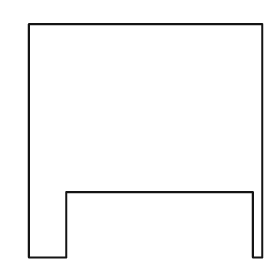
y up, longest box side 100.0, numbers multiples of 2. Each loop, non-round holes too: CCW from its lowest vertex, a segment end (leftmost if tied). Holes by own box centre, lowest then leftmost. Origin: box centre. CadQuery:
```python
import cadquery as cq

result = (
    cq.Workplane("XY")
    .moveTo(-50.0, -50.0)
    .lineTo(-34.0, -50.0)
    .lineTo(-34.0, -22.0)
    .lineTo(46.0, -22.0)
    .lineTo(46.0, -50.0)
    .lineTo(50.0, -50.0)
    .lineTo(50.0, 50.0)
    .lineTo(-50.0, 50.0)
    .close()
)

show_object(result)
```